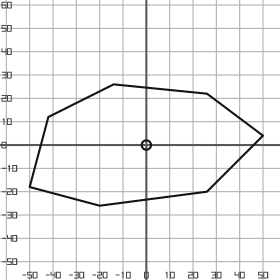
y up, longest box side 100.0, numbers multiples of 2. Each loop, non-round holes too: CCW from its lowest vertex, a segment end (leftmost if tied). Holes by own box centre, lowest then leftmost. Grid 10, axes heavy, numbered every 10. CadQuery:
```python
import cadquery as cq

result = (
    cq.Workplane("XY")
    .moveTo(-20.0, -26.0)
    .lineTo(26.0, -20.0)
    .lineTo(50.0, 4.0)
    .lineTo(26.0, 22.0)
    .lineTo(-14.0, 26.0)
    .lineTo(-42.0, 12.0)
    .lineTo(-50.0, -18.0)
    .close()
    .moveTo(0.0, 0.0)
    .circle(2.0)
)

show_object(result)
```